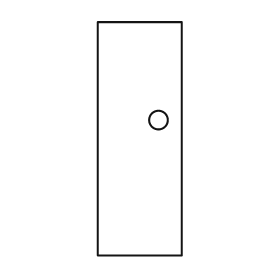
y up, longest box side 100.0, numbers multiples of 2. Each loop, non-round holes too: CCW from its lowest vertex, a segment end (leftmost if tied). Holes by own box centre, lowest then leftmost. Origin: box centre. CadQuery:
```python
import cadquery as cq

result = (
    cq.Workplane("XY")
    .moveTo(-18.0, -50.0)
    .lineTo(18.0, -50.0)
    .lineTo(18.0, 50.0)
    .lineTo(-18.0, 50.0)
    .close()
    .moveTo(8.0, 8.0)
    .circle(4.0)
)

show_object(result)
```